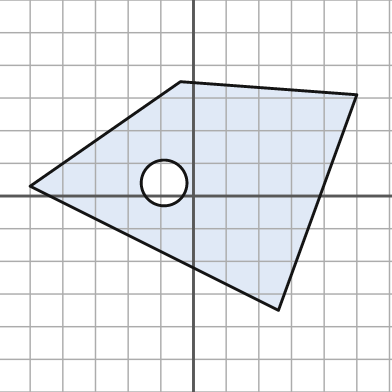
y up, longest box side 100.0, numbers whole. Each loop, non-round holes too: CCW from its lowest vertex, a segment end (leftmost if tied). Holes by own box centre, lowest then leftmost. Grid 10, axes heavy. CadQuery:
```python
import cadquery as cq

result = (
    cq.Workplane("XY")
    .moveTo(26.0, -35.0)
    .lineTo(50.0, 31.0)
    .lineTo(-4.0, 35.0)
    .lineTo(-50.0, 3.0)
    .close()
    .moveTo(-9.0, 4.0)
    .circle(7.0)
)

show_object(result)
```